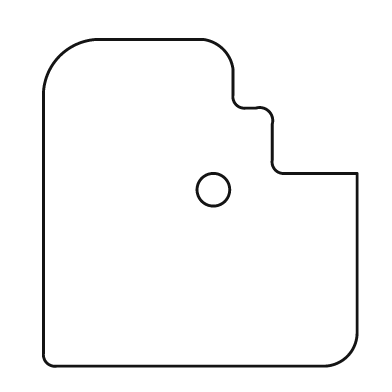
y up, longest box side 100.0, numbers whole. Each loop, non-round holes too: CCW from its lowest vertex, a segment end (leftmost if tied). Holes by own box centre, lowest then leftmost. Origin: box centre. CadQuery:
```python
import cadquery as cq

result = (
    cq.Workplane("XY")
    .moveTo(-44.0, -50.0)
    .lineTo(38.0, -50.0)
    .threePointArc((45.0, -47.0), (48.0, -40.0))
    .lineTo(48.0, 9.0)
    .lineTo(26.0, 9.0)
    .threePointArc((23.0, 10.0), (22.0, 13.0))
    .lineTo(22.0, 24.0)
    .threePointArc((21.0, 28.0), (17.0, 29.0))
    .lineTo(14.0, 29.0)
    .threePointArc((11.0, 30.0), (10.0, 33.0))
    .lineTo(10.0, 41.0)
    .threePointArc((7.0, 47.0), (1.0, 50.0))
    .lineTo(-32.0, 50.0)
    .threePointArc((-43.0, 45.0), (-48.0, 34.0))
    .lineTo(-48.0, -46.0)
    .threePointArc((-47.0, -49.0), (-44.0, -50.0))
    .close()
    .moveTo(4.0, 4.0)
    .circle(5.0)
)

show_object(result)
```